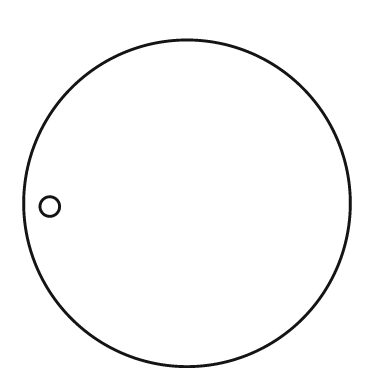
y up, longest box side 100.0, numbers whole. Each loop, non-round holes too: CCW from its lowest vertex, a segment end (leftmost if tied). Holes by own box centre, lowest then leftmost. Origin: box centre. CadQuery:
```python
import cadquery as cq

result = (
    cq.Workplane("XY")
    .moveTo(0.0, 0.0)
    .circle(50.0)
    .moveTo(-42.0, -1.0)
    .circle(3.0)
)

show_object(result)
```